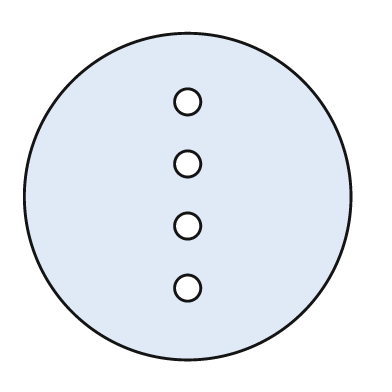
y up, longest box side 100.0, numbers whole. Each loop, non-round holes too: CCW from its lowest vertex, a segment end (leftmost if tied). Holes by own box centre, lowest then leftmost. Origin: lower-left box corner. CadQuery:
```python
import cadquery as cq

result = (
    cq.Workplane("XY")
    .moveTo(50.0, 50.0)
    .circle(50.0)
    .moveTo(50.0, 22.0)
    .circle(4.0)
    .moveTo(50.0, 41.0)
    .circle(4.0)
    .moveTo(50.0, 60.0)
    .circle(4.0)
    .moveTo(50.0, 79.0)
    .circle(4.0)
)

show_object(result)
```